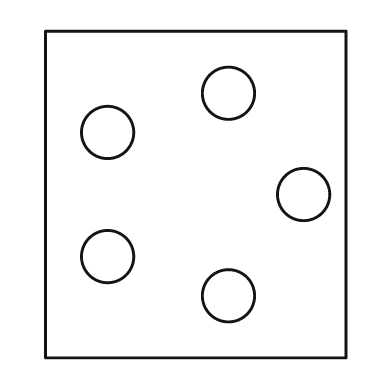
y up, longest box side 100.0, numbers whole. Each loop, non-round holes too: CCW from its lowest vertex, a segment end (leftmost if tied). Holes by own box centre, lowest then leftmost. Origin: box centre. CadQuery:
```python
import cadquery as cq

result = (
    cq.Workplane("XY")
    .moveTo(-46.0, -50.0)
    .lineTo(46.0, -50.0)
    .lineTo(46.0, 50.0)
    .lineTo(-46.0, 50.0)
    .close()
    .moveTo(10.0, -31.0)
    .circle(8.0)
    .moveTo(-27.0, -19.0)
    .circle(8.0)
    .moveTo(33.0, 0.0)
    .circle(8.0)
    .moveTo(-27.0, 19.0)
    .circle(8.0)
    .moveTo(10.0, 31.0)
    .circle(8.0)
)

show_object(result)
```